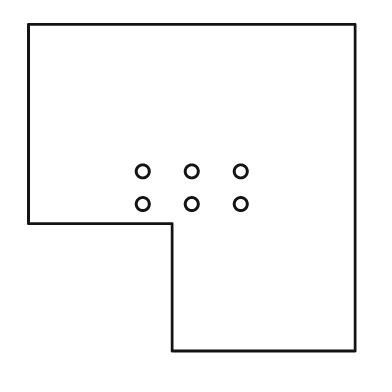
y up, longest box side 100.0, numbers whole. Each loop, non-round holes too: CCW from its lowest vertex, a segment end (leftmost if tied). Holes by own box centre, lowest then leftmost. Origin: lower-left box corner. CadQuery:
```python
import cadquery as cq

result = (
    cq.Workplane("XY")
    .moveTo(44.0, 0.0)
    .lineTo(100.0, 0.0)
    .lineTo(100.0, 100.0)
    .lineTo(0.0, 100.0)
    .lineTo(0.0, 39.0)
    .lineTo(44.0, 39.0)
    .close()
    .moveTo(35.0, 45.0)
    .circle(2.0)
    .moveTo(50.0, 45.0)
    .circle(2.0)
    .moveTo(65.0, 45.0)
    .circle(2.0)
    .moveTo(35.0, 55.0)
    .circle(2.0)
    .moveTo(50.0, 55.0)
    .circle(2.0)
    .moveTo(65.0, 55.0)
    .circle(2.0)
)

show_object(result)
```